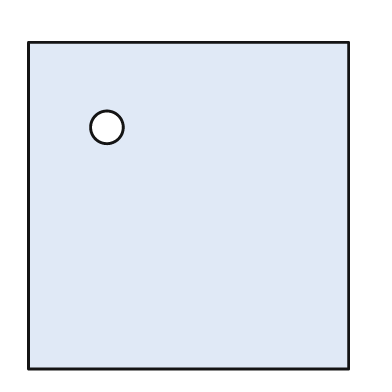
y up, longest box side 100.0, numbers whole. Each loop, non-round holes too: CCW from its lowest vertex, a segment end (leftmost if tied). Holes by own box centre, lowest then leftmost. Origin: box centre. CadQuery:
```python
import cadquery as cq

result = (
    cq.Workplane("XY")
    .moveTo(-49.0, -50.0)
    .lineTo(49.0, -50.0)
    .lineTo(49.0, 50.0)
    .lineTo(-49.0, 50.0)
    .close()
    .moveTo(-25.0, 24.0)
    .circle(5.0)
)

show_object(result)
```